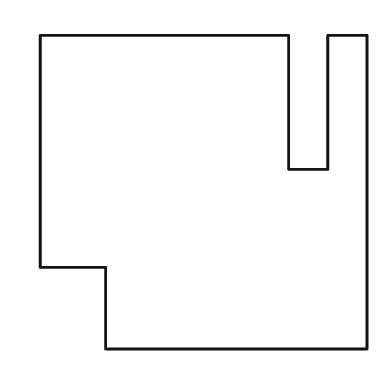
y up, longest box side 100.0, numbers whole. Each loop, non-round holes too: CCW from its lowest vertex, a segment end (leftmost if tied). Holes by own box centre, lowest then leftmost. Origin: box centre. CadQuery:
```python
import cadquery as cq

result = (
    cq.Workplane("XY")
    .moveTo(-30.0, -48.0)
    .lineTo(50.0, -48.0)
    .lineTo(50.0, 48.0)
    .lineTo(38.0, 48.0)
    .lineTo(38.0, 7.0)
    .lineTo(26.0, 7.0)
    .lineTo(26.0, 48.0)
    .lineTo(-50.0, 48.0)
    .lineTo(-50.0, -23.0)
    .lineTo(-30.0, -23.0)
    .close()
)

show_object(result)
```